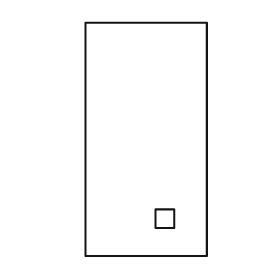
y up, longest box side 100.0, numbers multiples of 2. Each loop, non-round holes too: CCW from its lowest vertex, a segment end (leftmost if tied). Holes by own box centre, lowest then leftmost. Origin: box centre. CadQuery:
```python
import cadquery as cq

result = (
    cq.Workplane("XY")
    .moveTo(-26.0, -50.0)
    .lineTo(26.0, -50.0)
    .lineTo(26.0, 50.0)
    .lineTo(-26.0, 50.0)
    .close()
    .moveTo(4.0, -38.0)
    .lineTo(12.0, -38.0)
    .lineTo(12.0, -30.0)
    .lineTo(4.0, -30.0)
    .close()
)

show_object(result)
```